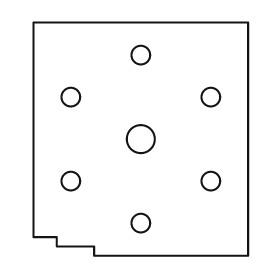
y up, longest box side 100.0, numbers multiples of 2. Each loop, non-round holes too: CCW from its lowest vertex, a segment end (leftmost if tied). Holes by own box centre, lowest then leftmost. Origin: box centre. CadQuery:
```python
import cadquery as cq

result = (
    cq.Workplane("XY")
    .moveTo(-20.0, -50.0)
    .lineTo(46.0, -50.0)
    .lineTo(46.0, 50.0)
    .lineTo(-46.0, 50.0)
    .lineTo(-46.0, -42.0)
    .lineTo(-36.0, -42.0)
    .lineTo(-36.0, -46.0)
    .lineTo(-20.0, -46.0)
    .close()
    .moveTo(0.0, -36.0)
    .circle(4.0)
    .moveTo(-30.0, -18.0)
    .circle(4.0)
    .moveTo(30.0, -18.0)
    .circle(4.0)
    .moveTo(0.0, 0.0)
    .circle(6.0)
    .moveTo(-30.0, 18.0)
    .circle(4.0)
    .moveTo(30.0, 18.0)
    .circle(4.0)
    .moveTo(0.0, 36.0)
    .circle(4.0)
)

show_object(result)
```